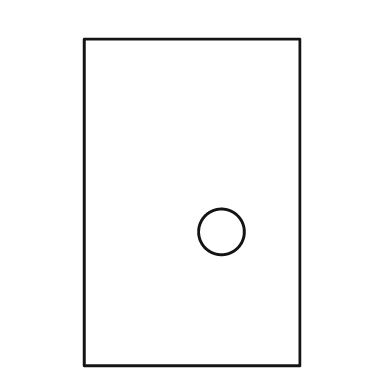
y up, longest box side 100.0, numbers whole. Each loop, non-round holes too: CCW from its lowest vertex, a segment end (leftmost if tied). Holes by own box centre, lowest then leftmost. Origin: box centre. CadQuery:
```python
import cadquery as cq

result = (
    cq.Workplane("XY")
    .moveTo(-33.0, -50.0)
    .lineTo(33.0, -50.0)
    .lineTo(33.0, 50.0)
    .lineTo(-33.0, 50.0)
    .close()
    .moveTo(9.0, -9.0)
    .circle(7.0)
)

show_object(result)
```